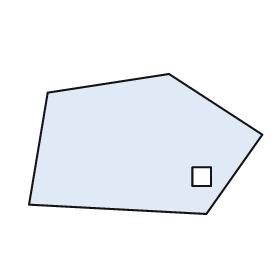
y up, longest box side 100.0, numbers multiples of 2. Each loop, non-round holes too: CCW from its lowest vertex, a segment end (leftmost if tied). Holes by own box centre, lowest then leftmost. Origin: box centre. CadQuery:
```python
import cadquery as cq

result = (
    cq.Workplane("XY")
    .moveTo(26.0, -30.0)
    .lineTo(50.0, 4.0)
    .lineTo(10.0, 30.0)
    .lineTo(-42.0, 22.0)
    .lineTo(-50.0, -26.0)
    .close()
    .moveTo(20.0, -18.0)
    .lineTo(28.0, -18.0)
    .lineTo(28.0, -10.0)
    .lineTo(20.0, -10.0)
    .close()
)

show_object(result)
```